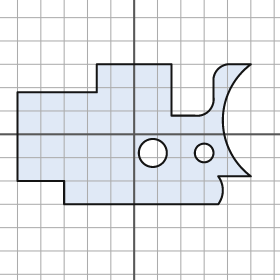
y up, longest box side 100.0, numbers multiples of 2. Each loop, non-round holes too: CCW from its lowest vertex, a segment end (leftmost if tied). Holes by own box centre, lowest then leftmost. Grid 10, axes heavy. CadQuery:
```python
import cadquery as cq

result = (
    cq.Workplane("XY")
    .moveTo(-30.0, -30.0)
    .lineTo(36.0, -30.0)
    .threePointArc((38.0, -24.0), (36.0, -18.0))
    .lineTo(50.0, -18.0)
    .threePointArc((38.0, 6.0), (50.0, 30.0))
    .lineTo(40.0, 30.0)
    .threePointArc((36.0, 28.0), (34.0, 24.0))
    .lineTo(34.0, 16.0)
    .threePointArc((32.0, 10.0), (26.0, 8.0))
    .lineTo(16.0, 8.0)
    .lineTo(16.0, 30.0)
    .lineTo(-16.0, 30.0)
    .lineTo(-16.0, 18.0)
    .lineTo(-50.0, 18.0)
    .lineTo(-50.0, -20.0)
    .lineTo(-30.0, -20.0)
    .close()
    .moveTo(8.0, -8.0)
    .circle(6.0)
    .moveTo(30.0, -8.0)
    .circle(4.0)
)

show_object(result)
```